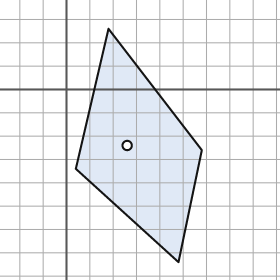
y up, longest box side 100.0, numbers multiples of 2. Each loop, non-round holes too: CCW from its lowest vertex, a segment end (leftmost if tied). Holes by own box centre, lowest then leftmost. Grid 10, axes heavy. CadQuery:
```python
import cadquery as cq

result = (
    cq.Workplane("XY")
    .moveTo(48.0, -74.0)
    .lineTo(58.0, -26.0)
    .lineTo(18.0, 26.0)
    .lineTo(4.0, -34.0)
    .close()
    .moveTo(26.0, -24.0)
    .circle(2.0)
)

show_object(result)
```